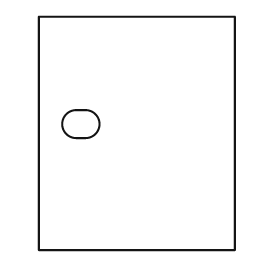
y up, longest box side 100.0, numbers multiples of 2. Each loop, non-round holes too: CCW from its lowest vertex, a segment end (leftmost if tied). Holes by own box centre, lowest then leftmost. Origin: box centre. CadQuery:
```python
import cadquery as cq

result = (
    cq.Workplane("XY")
    .moveTo(-42.0, -50.0)
    .lineTo(42.0, -50.0)
    .lineTo(42.0, 50.0)
    .lineTo(-42.0, 50.0)
    .close()
    .moveTo(-26.0, -2.0)
    .lineTo(-22.0, -2.0)
    .threePointArc((-16.0, 4.0), (-22.0, 10.0))
    .lineTo(-26.0, 10.0)
    .threePointArc((-32.0, 4.0), (-26.0, -2.0))
    .close()
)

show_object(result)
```